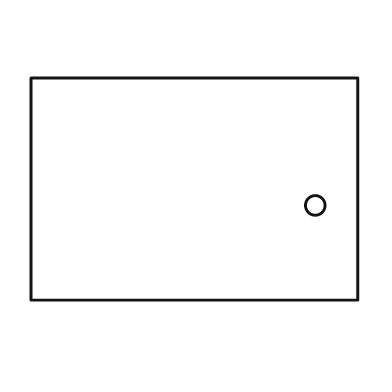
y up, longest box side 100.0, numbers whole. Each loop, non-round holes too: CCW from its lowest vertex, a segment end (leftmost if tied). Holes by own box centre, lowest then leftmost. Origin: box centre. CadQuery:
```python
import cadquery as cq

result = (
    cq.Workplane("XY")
    .moveTo(-50.0, -34.0)
    .lineTo(50.0, -34.0)
    .lineTo(50.0, 34.0)
    .lineTo(-50.0, 34.0)
    .close()
    .moveTo(37.0, -5.0)
    .circle(3.0)
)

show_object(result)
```